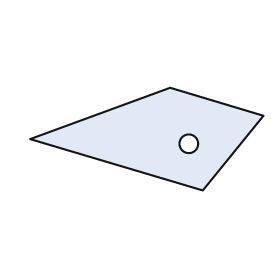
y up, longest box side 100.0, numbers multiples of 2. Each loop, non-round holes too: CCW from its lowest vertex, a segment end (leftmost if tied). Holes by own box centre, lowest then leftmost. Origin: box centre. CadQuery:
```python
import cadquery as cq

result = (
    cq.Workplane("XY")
    .moveTo(24.0, -22.0)
    .lineTo(50.0, 10.0)
    .lineTo(10.0, 22.0)
    .lineTo(-50.0, 0.0)
    .close()
    .moveTo(18.0, -2.0)
    .circle(4.0)
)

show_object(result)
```